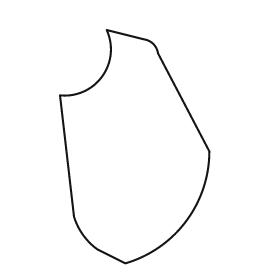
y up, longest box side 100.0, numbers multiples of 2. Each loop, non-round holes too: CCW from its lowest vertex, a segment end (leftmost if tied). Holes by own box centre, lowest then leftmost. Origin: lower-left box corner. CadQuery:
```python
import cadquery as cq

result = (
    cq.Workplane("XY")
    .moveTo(28.0, 0.0)
    .threePointArc((54.0, 18.0), (64.0, 48.0))
    .lineTo(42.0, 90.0)
    .threePointArc((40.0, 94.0), (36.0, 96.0))
    .lineTo(20.0, 100.0)
    .threePointArc((18.0, 80.0), (0.0, 72.0))
    .lineTo(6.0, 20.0)
    .threePointArc((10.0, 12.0), (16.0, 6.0))
    .close()
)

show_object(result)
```